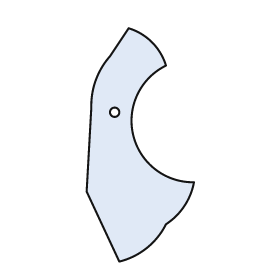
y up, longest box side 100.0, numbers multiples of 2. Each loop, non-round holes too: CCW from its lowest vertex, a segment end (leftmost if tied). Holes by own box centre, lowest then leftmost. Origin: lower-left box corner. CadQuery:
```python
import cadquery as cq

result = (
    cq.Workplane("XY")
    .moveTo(14.0, 0.0)
    .threePointArc((26.0, 6.0), (34.0, 16.0))
    .threePointArc((42.0, 24.0), (46.0, 34.0))
    .threePointArc((20.0, 54.0), (34.0, 84.0))
    .threePointArc((28.0, 94.0), (18.0, 100.0))
    .lineTo(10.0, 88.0)
    .threePointArc((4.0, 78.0), (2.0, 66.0))
    .lineTo(0.0, 30.0)
    .close()
    .moveTo(12.0, 64.0)
    .circle(2.0)
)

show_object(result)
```